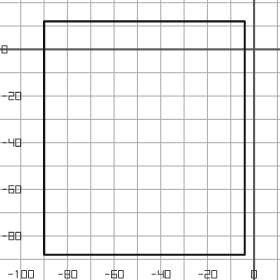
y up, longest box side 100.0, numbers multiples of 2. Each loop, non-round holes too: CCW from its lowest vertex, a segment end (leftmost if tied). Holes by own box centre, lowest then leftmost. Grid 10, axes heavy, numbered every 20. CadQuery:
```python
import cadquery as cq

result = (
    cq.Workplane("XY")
    .moveTo(-90.0, -88.0)
    .lineTo(-4.0, -88.0)
    .lineTo(-4.0, 12.0)
    .lineTo(-90.0, 12.0)
    .close()
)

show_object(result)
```